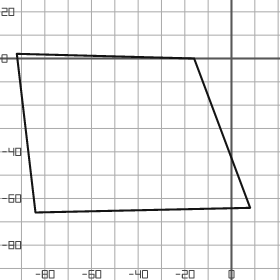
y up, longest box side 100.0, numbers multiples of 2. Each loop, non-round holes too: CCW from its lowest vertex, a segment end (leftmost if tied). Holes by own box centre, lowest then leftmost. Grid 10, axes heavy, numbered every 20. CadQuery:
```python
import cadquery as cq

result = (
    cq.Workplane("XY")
    .moveTo(-84.0, -66.0)
    .lineTo(8.0, -64.0)
    .lineTo(-16.0, 0.0)
    .lineTo(-92.0, 2.0)
    .close()
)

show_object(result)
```